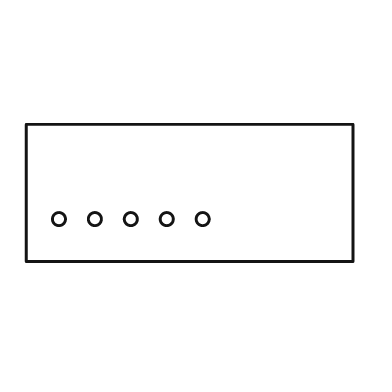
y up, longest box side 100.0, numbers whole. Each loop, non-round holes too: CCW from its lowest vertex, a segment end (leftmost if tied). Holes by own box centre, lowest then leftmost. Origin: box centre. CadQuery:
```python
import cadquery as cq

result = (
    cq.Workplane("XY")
    .moveTo(-50.0, -21.0)
    .lineTo(50.0, -21.0)
    .lineTo(50.0, 21.0)
    .lineTo(-50.0, 21.0)
    .close()
    .moveTo(-40.0, -8.0)
    .circle(2.0)
    .moveTo(-29.0, -8.0)
    .circle(2.0)
    .moveTo(-18.0, -8.0)
    .circle(2.0)
    .moveTo(-7.0, -8.0)
    .circle(2.0)
    .moveTo(4.0, -8.0)
    .circle(2.0)
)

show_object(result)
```